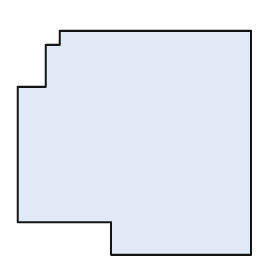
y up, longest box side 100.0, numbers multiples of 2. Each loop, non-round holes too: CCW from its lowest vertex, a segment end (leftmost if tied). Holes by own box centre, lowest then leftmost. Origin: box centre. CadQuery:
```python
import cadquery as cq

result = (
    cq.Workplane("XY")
    .moveTo(-10.0, -48.0)
    .lineTo(50.0, -48.0)
    .lineTo(50.0, 48.0)
    .lineTo(-32.0, 48.0)
    .lineTo(-32.0, 42.0)
    .lineTo(-38.0, 42.0)
    .lineTo(-38.0, 24.0)
    .lineTo(-50.0, 24.0)
    .lineTo(-50.0, -34.0)
    .lineTo(-10.0, -34.0)
    .close()
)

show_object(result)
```